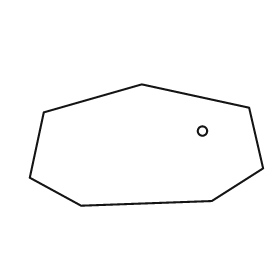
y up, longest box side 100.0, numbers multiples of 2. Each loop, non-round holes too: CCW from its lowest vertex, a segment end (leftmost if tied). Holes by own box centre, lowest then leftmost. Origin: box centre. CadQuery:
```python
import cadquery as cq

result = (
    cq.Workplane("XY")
    .moveTo(-28.0, -26.0)
    .lineTo(28.0, -24.0)
    .lineTo(50.0, -10.0)
    .lineTo(44.0, 16.0)
    .lineTo(-2.0, 26.0)
    .lineTo(-44.0, 14.0)
    .lineTo(-50.0, -14.0)
    .close()
    .moveTo(24.0, 6.0)
    .circle(2.0)
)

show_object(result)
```